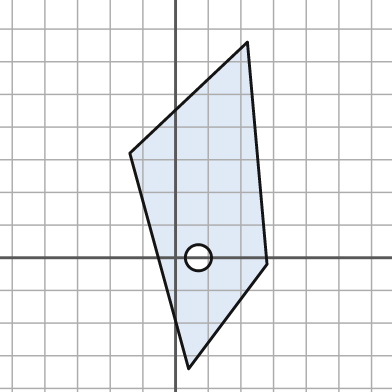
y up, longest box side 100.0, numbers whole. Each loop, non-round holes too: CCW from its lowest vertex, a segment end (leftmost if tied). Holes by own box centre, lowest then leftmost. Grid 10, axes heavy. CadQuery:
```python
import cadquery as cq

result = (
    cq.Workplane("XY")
    .moveTo(4.0, -34.0)
    .lineTo(28.0, -2.0)
    .lineTo(22.0, 66.0)
    .lineTo(-14.0, 32.0)
    .close()
    .moveTo(7.0, 0.0)
    .circle(4.0)
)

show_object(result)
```